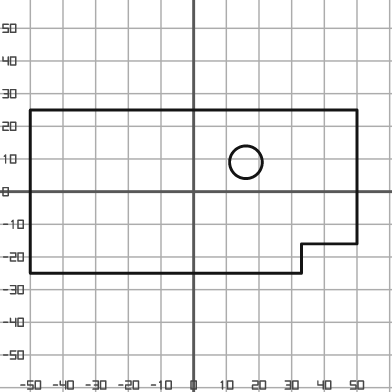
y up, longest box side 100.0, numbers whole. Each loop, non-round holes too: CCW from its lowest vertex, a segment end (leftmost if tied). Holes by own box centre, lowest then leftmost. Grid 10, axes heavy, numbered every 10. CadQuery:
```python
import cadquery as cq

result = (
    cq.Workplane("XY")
    .moveTo(-50.0, -25.0)
    .lineTo(33.0, -25.0)
    .lineTo(33.0, -16.0)
    .lineTo(50.0, -16.0)
    .lineTo(50.0, 25.0)
    .lineTo(-50.0, 25.0)
    .close()
    .moveTo(16.0, 9.0)
    .circle(5.0)
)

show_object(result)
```